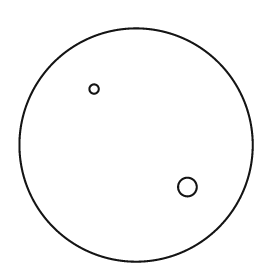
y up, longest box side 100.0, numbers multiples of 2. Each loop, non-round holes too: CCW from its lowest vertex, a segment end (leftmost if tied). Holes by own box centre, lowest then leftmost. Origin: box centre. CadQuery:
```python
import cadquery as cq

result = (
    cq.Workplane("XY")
    .moveTo(0.0, 0.0)
    .circle(50.0)
    .moveTo(22.0, -18.0)
    .circle(4.0)
    .moveTo(-18.0, 24.0)
    .circle(2.0)
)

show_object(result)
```